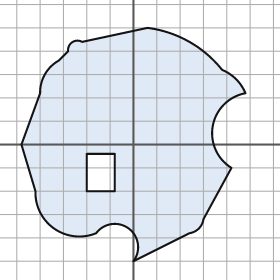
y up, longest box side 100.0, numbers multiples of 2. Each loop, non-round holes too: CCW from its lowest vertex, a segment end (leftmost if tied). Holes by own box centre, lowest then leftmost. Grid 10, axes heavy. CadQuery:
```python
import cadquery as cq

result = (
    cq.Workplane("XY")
    .moveTo(0.0, -50.0)
    .lineTo(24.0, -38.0)
    .threePointArc((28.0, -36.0), (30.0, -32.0))
    .lineTo(42.0, -10.0)
    .threePointArc((34.0, 8.0), (48.0, 22.0))
    .threePointArc((44.0, 28.0), (38.0, 32.0))
    .threePointArc((24.0, 44.0), (6.0, 50.0))
    .lineTo(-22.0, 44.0)
    .threePointArc((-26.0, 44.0), (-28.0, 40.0))
    .lineTo(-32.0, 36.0)
    .threePointArc((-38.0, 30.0), (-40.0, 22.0))
    .lineTo(-48.0, 0.0)
    .lineTo(-42.0, -20.0)
    .threePointArc((-34.0, -36.0), (-16.0, -38.0))
    .threePointArc((-2.0, -36.0), (0.0, -50.0))
    .close()
    .moveTo(-20.0, -20.0)
    .lineTo(-8.0, -20.0)
    .lineTo(-8.0, -4.0)
    .lineTo(-20.0, -4.0)
    .close()
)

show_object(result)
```